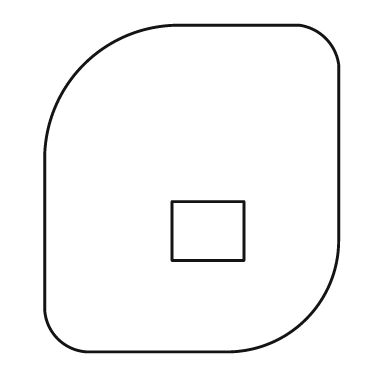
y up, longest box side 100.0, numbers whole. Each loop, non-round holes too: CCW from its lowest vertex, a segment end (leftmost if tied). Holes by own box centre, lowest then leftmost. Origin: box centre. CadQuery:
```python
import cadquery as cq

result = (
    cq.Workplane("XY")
    .moveTo(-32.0, -50.0)
    .lineTo(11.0, -50.0)
    .threePointArc((35.0, -40.0), (45.0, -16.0))
    .lineTo(45.0, 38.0)
    .threePointArc((41.0, 46.0), (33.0, 50.0))
    .lineTo(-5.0, 50.0)
    .threePointArc((-33.0, 38.0), (-45.0, 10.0))
    .lineTo(-45.0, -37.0)
    .threePointArc((-41.0, -46.0), (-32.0, -50.0))
    .close()
    .moveTo(-6.0, -22.0)
    .lineTo(16.0, -22.0)
    .lineTo(16.0, -4.0)
    .lineTo(-6.0, -4.0)
    .close()
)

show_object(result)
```